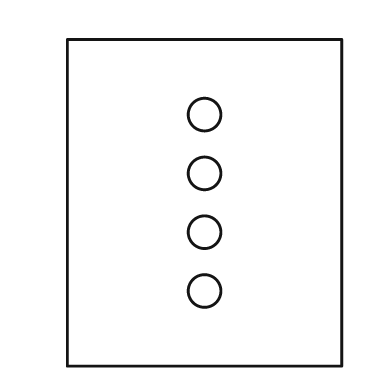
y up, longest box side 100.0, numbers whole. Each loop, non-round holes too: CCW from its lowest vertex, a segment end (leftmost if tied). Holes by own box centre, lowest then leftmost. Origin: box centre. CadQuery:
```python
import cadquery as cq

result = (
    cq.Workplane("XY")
    .moveTo(-42.0, -50.0)
    .lineTo(42.0, -50.0)
    .lineTo(42.0, 50.0)
    .lineTo(-42.0, 50.0)
    .close()
    .moveTo(0.0, -27.0)
    .circle(5.0)
    .moveTo(0.0, -9.0)
    .circle(5.0)
    .moveTo(0.0, 9.0)
    .circle(5.0)
    .moveTo(0.0, 27.0)
    .circle(5.0)
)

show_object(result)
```